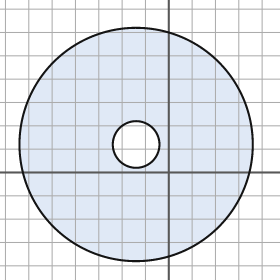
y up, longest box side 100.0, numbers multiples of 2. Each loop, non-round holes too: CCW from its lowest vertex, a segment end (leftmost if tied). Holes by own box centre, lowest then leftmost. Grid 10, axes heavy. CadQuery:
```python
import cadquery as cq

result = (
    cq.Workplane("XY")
    .moveTo(-14.0, 12.0)
    .circle(50.0)
    .moveTo(-14.0, 12.0)
    .circle(10.0)
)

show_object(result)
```